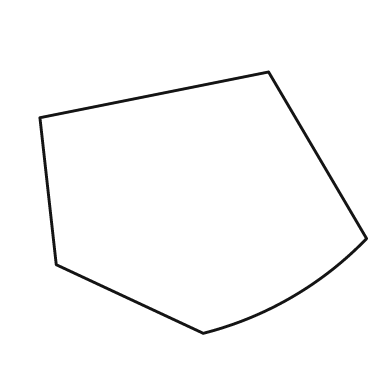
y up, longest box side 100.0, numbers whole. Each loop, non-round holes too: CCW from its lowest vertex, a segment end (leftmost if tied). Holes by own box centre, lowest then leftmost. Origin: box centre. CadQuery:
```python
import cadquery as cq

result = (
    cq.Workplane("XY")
    .moveTo(0.0, -40.0)
    .threePointArc((27.0, -29.0), (50.0, -11.0))
    .lineTo(20.0, 40.0)
    .lineTo(-50.0, 26.0)
    .lineTo(-45.0, -19.0)
    .close()
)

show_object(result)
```